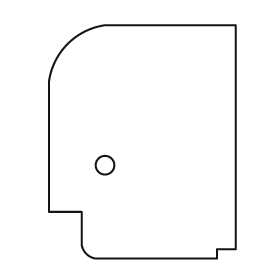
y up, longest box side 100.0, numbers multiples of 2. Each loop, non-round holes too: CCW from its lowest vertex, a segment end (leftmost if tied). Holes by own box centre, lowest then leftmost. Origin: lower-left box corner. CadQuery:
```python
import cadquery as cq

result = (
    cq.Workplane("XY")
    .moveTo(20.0, 0.0)
    .lineTo(72.0, 0.0)
    .lineTo(72.0, 4.0)
    .lineTo(80.0, 4.0)
    .lineTo(80.0, 100.0)
    .lineTo(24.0, 100.0)
    .threePointArc((8.0, 92.0), (0.0, 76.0))
    .lineTo(0.0, 20.0)
    .lineTo(14.0, 20.0)
    .lineTo(14.0, 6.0)
    .threePointArc((16.0, 2.0), (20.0, 0.0))
    .close()
    .moveTo(24.0, 40.0)
    .circle(4.0)
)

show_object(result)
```